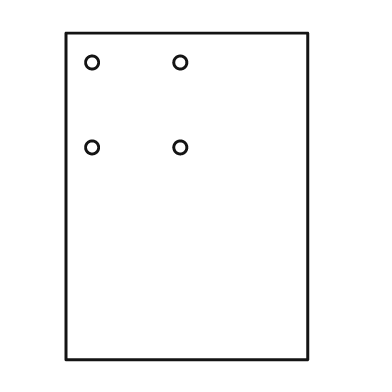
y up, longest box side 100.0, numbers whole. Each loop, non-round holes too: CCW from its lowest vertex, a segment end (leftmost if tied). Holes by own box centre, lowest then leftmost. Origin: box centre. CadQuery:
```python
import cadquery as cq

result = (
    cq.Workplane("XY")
    .moveTo(-37.0, -50.0)
    .lineTo(37.0, -50.0)
    .lineTo(37.0, 50.0)
    .lineTo(-37.0, 50.0)
    .close()
    .moveTo(-29.0, 15.0)
    .circle(2.0)
    .moveTo(-2.0, 15.0)
    .circle(2.0)
    .moveTo(-29.0, 41.0)
    .circle(2.0)
    .moveTo(-2.0, 41.0)
    .circle(2.0)
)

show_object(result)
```